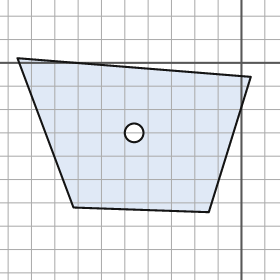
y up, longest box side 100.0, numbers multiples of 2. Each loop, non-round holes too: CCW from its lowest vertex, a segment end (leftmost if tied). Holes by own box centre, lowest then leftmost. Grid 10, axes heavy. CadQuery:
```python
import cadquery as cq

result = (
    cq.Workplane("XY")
    .moveTo(-14.0, -64.0)
    .lineTo(4.0, -6.0)
    .lineTo(-96.0, 2.0)
    .lineTo(-72.0, -62.0)
    .close()
    .moveTo(-46.0, -30.0)
    .circle(4.0)
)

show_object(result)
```